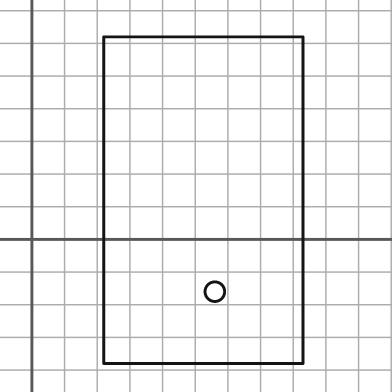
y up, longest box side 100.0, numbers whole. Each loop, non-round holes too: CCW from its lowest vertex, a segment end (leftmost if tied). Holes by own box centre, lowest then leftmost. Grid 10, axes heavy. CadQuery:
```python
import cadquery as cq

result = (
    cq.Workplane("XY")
    .moveTo(22.0, -38.0)
    .lineTo(83.0, -38.0)
    .lineTo(83.0, 62.0)
    .lineTo(22.0, 62.0)
    .close()
    .moveTo(56.0, -16.0)
    .circle(3.0)
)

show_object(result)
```